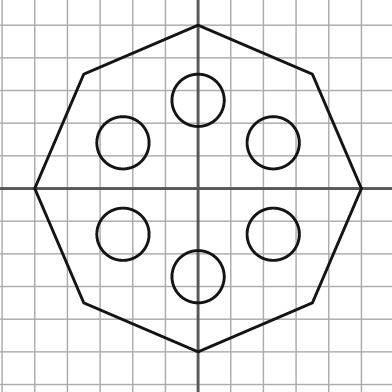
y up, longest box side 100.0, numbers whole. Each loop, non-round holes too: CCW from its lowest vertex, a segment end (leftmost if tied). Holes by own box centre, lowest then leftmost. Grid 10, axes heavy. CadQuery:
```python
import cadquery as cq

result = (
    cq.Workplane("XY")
    .moveTo(0.0, -50.0)
    .lineTo(35.0, -35.0)
    .lineTo(50.0, 0.0)
    .lineTo(35.0, 35.0)
    .lineTo(0.0, 50.0)
    .lineTo(-35.0, 35.0)
    .lineTo(-50.0, 0.0)
    .lineTo(-35.0, -35.0)
    .close()
    .moveTo(0.0, -27.0)
    .circle(8.0)
    .moveTo(-23.0, -14.0)
    .circle(8.0)
    .moveTo(23.0, -14.0)
    .circle(8.0)
    .moveTo(-23.0, 14.0)
    .circle(8.0)
    .moveTo(23.0, 14.0)
    .circle(8.0)
    .moveTo(0.0, 27.0)
    .circle(8.0)
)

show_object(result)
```